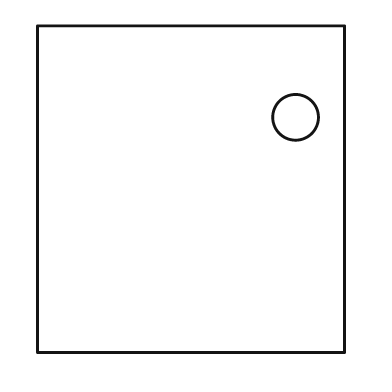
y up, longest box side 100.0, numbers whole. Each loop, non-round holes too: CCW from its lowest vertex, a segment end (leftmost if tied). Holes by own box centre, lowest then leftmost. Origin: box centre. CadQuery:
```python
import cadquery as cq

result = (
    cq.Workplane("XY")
    .moveTo(-47.0, -50.0)
    .lineTo(47.0, -50.0)
    .lineTo(47.0, 50.0)
    .lineTo(-47.0, 50.0)
    .close()
    .moveTo(32.0, 22.0)
    .circle(7.0)
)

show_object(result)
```